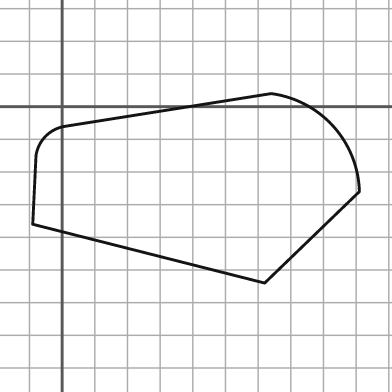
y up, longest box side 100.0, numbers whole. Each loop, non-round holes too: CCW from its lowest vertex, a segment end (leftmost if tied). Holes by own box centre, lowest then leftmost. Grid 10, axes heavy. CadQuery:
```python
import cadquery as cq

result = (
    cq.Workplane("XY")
    .moveTo(62.0, -54.0)
    .lineTo(91.0, -26.0)
    .threePointArc((83.0, -6.0), (64.0, 4.0))
    .lineTo(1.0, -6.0)
    .threePointArc((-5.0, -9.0), (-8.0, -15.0))
    .lineTo(-9.0, -36.0)
    .close()
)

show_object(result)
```